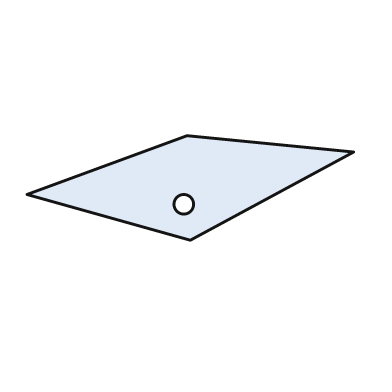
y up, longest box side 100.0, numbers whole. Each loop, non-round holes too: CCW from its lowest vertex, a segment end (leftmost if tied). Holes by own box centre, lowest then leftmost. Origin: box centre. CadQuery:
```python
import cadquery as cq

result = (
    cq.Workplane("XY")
    .moveTo(0.0, -16.0)
    .lineTo(50.0, 11.0)
    .lineTo(-1.0, 16.0)
    .lineTo(-50.0, -2.0)
    .close()
    .moveTo(-2.0, -5.0)
    .circle(3.0)
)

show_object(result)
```